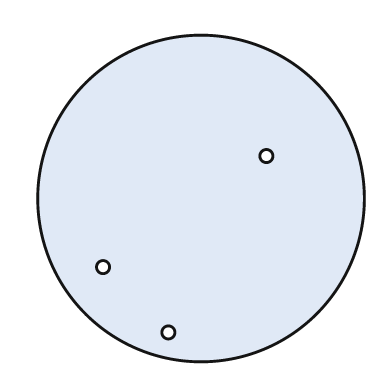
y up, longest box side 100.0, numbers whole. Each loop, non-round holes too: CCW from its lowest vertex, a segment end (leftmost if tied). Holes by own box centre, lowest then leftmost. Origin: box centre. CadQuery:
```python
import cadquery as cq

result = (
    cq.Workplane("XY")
    .moveTo(0.0, 0.0)
    .circle(50.0)
    .moveTo(-10.0, -41.0)
    .circle(2.0)
    .moveTo(-30.0, -21.0)
    .circle(2.0)
    .moveTo(20.0, 13.0)
    .circle(2.0)
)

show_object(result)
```